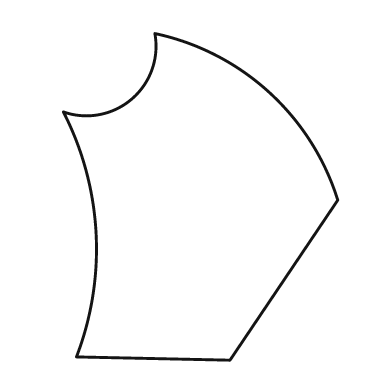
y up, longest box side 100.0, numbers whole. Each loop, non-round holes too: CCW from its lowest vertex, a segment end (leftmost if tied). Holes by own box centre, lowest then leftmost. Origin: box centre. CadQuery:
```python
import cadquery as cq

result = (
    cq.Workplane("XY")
    .moveTo(9.0, -50.0)
    .lineTo(42.0, -1.0)
    .threePointArc((21.0, 32.0), (-14.0, 50.0))
    .threePointArc((-21.0, 30.0), (-42.0, 26.0))
    .threePointArc((-32.0, -11.0), (-38.0, -49.0))
    .close()
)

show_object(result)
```